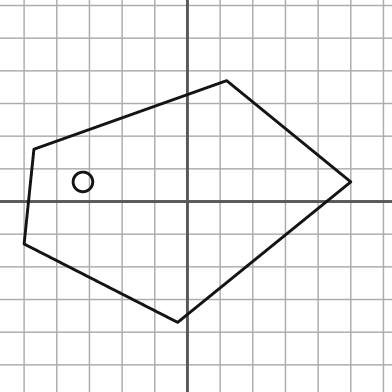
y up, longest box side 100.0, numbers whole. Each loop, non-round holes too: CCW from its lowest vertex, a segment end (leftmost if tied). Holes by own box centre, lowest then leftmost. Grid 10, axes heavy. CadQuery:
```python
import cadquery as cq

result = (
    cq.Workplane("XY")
    .moveTo(-3.0, -37.0)
    .lineTo(50.0, 6.0)
    .lineTo(12.0, 37.0)
    .lineTo(-47.0, 16.0)
    .lineTo(-50.0, -13.0)
    .close()
    .moveTo(-32.0, 6.0)
    .circle(3.0)
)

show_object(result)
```